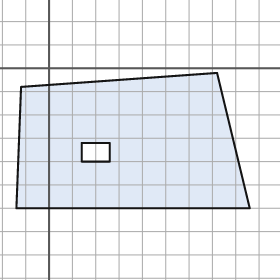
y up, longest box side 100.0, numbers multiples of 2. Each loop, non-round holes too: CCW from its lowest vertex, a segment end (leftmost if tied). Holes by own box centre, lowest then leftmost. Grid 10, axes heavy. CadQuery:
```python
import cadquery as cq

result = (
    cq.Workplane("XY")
    .moveTo(-14.0, -60.0)
    .lineTo(86.0, -60.0)
    .lineTo(72.0, -2.0)
    .lineTo(-12.0, -8.0)
    .close()
    .moveTo(14.0, -40.0)
    .lineTo(26.0, -40.0)
    .lineTo(26.0, -32.0)
    .lineTo(14.0, -32.0)
    .close()
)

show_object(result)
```